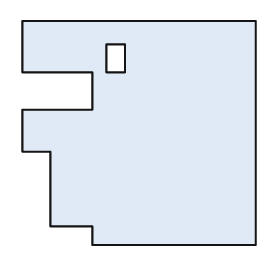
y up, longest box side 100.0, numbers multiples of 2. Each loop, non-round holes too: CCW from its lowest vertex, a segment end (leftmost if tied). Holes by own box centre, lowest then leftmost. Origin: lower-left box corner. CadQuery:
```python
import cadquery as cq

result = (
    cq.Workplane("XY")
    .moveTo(30.0, 0.0)
    .lineTo(100.0, 0.0)
    .lineTo(100.0, 96.0)
    .lineTo(0.0, 96.0)
    .lineTo(0.0, 74.0)
    .lineTo(30.0, 74.0)
    .lineTo(30.0, 58.0)
    .lineTo(0.0, 58.0)
    .lineTo(0.0, 40.0)
    .lineTo(12.0, 40.0)
    .lineTo(12.0, 8.0)
    .lineTo(30.0, 8.0)
    .close()
    .moveTo(36.0, 74.0)
    .lineTo(44.0, 74.0)
    .lineTo(44.0, 86.0)
    .lineTo(36.0, 86.0)
    .close()
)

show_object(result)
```